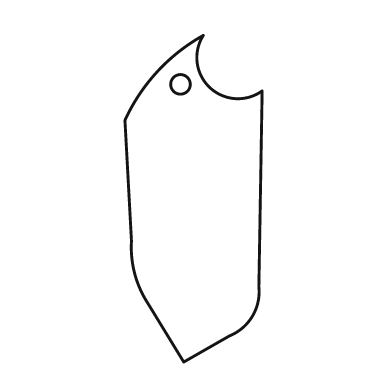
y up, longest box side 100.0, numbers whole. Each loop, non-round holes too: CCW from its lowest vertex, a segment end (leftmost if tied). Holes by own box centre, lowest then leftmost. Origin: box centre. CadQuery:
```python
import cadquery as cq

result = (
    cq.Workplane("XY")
    .moveTo(-3.0, -50.0)
    .lineTo(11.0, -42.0)
    .threePointArc((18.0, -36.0), (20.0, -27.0))
    .lineTo(21.0, 33.0)
    .threePointArc((5.0, 34.0), (3.0, 50.0))
    .threePointArc((-11.0, 39.0), (-21.0, 24.0))
    .lineTo(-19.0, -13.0)
    .threePointArc((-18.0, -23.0), (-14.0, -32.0))
    .close()
    .moveTo(-4.0, 35.0)
    .circle(3.0)
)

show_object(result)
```